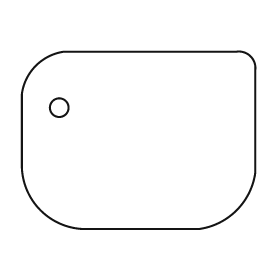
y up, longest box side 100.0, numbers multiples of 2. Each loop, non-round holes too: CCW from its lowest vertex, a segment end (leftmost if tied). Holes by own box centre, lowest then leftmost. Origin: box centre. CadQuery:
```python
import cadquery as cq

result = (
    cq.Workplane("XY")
    .moveTo(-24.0, -38.0)
    .lineTo(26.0, -38.0)
    .threePointArc((42.0, -30.0), (50.0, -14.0))
    .lineTo(50.0, 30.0)
    .threePointArc((48.0, 36.0), (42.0, 38.0))
    .lineTo(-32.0, 38.0)
    .threePointArc((-44.0, 32.0), (-50.0, 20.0))
    .lineTo(-50.0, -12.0)
    .threePointArc((-42.0, -30.0), (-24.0, -38.0))
    .close()
    .moveTo(-34.0, 14.0)
    .circle(4.0)
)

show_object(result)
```